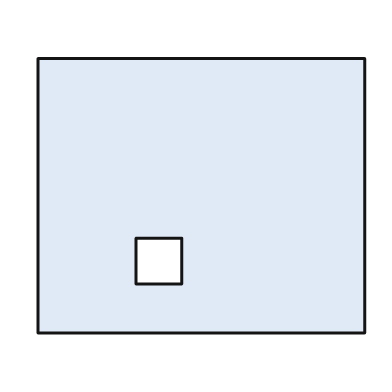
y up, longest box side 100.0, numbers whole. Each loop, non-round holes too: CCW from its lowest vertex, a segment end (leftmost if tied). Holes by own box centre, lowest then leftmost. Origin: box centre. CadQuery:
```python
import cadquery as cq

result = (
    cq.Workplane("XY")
    .moveTo(-50.0, -42.0)
    .lineTo(50.0, -42.0)
    .lineTo(50.0, 42.0)
    .lineTo(-50.0, 42.0)
    .close()
    .moveTo(-20.0, -27.0)
    .lineTo(-6.0, -27.0)
    .lineTo(-6.0, -13.0)
    .lineTo(-20.0, -13.0)
    .close()
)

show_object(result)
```